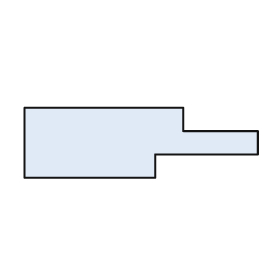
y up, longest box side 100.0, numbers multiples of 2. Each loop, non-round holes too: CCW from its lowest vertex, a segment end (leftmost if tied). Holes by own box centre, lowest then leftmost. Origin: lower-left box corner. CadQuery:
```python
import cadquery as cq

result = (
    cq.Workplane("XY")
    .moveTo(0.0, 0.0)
    .lineTo(56.0, 0.0)
    .lineTo(56.0, 10.0)
    .lineTo(100.0, 10.0)
    .lineTo(100.0, 20.0)
    .lineTo(68.0, 20.0)
    .lineTo(68.0, 30.0)
    .lineTo(0.0, 30.0)
    .close()
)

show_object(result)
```